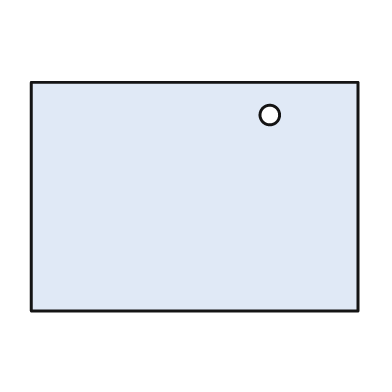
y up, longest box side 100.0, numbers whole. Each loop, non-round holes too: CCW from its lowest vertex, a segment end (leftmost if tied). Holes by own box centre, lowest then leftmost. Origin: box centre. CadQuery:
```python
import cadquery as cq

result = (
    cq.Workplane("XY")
    .moveTo(-50.0, -35.0)
    .lineTo(50.0, -35.0)
    .lineTo(50.0, 35.0)
    .lineTo(-50.0, 35.0)
    .close()
    .moveTo(23.0, 25.0)
    .circle(3.0)
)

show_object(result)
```